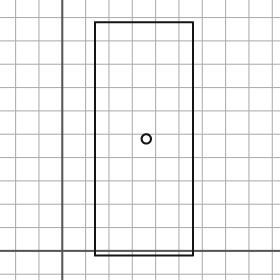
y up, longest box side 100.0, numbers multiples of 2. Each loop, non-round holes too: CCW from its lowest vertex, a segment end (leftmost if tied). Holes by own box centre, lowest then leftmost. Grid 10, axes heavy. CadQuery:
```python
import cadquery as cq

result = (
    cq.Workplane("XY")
    .moveTo(14.0, -2.0)
    .lineTo(56.0, -2.0)
    .lineTo(56.0, 98.0)
    .lineTo(14.0, 98.0)
    .close()
    .moveTo(36.0, 48.0)
    .circle(2.0)
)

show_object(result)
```